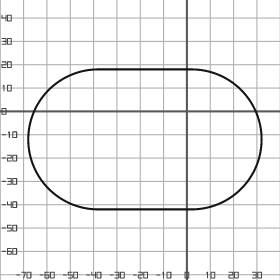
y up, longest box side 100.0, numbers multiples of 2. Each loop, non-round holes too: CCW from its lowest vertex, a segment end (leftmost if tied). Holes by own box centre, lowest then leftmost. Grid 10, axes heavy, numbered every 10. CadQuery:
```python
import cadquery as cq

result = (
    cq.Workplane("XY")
    .moveTo(-38.0, -42.0)
    .lineTo(2.0, -42.0)
    .threePointArc((32.0, -12.0), (2.0, 18.0))
    .lineTo(-38.0, 18.0)
    .threePointArc((-68.0, -12.0), (-38.0, -42.0))
    .close()
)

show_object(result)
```